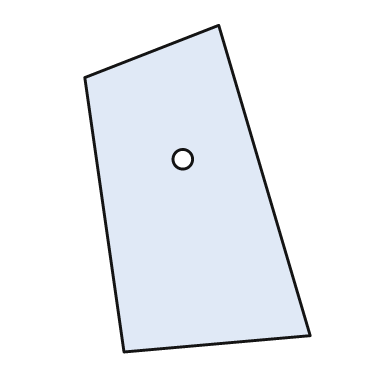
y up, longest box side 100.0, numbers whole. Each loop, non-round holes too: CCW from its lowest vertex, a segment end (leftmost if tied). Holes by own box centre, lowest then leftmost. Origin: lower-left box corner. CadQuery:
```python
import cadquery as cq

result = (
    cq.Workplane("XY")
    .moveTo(12.0, 0.0)
    .lineTo(69.0, 5.0)
    .lineTo(41.0, 100.0)
    .lineTo(0.0, 84.0)
    .close()
    .moveTo(30.0, 59.0)
    .circle(3.0)
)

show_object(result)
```